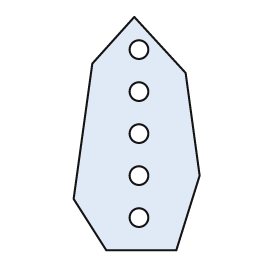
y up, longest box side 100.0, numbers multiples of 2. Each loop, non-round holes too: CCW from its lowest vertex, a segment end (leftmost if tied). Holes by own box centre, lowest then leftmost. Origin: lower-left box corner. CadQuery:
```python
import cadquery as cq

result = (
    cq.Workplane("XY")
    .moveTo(14.0, 0.0)
    .lineTo(44.0, 0.0)
    .lineTo(54.0, 32.0)
    .lineTo(48.0, 76.0)
    .lineTo(26.0, 100.0)
    .lineTo(8.0, 80.0)
    .lineTo(0.0, 22.0)
    .close()
    .moveTo(28.0, 14.0)
    .circle(4.0)
    .moveTo(28.0, 32.0)
    .circle(4.0)
    .moveTo(28.0, 50.0)
    .circle(4.0)
    .moveTo(28.0, 68.0)
    .circle(4.0)
    .moveTo(28.0, 86.0)
    .circle(4.0)
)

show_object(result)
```